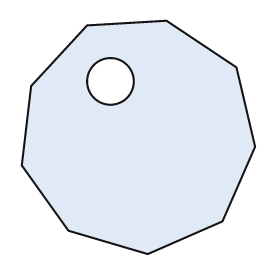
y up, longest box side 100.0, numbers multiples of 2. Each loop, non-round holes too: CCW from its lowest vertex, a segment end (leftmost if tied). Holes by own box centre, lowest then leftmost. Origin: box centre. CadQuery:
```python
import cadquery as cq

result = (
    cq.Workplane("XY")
    .moveTo(4.0, -50.0)
    .lineTo(36.0, -36.0)
    .lineTo(50.0, -4.0)
    .lineTo(42.0, 30.0)
    .lineTo(12.0, 50.0)
    .lineTo(-22.0, 48.0)
    .lineTo(-46.0, 22.0)
    .lineTo(-50.0, -12.0)
    .lineTo(-30.0, -40.0)
    .close()
    .moveTo(-12.0, 24.0)
    .circle(10.0)
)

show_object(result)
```